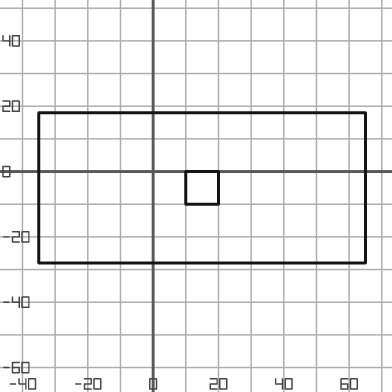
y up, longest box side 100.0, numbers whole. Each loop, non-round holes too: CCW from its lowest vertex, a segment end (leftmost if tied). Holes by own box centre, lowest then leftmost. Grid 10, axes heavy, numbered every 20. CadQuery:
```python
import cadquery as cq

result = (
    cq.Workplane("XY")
    .moveTo(-35.0, -28.0)
    .lineTo(65.0, -28.0)
    .lineTo(65.0, 18.0)
    .lineTo(-35.0, 18.0)
    .close()
    .moveTo(10.0, -10.0)
    .lineTo(20.0, -10.0)
    .lineTo(20.0, 0.0)
    .lineTo(10.0, 0.0)
    .close()
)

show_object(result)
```